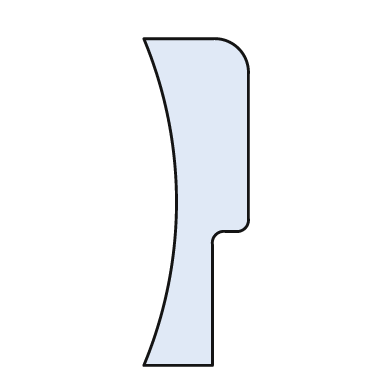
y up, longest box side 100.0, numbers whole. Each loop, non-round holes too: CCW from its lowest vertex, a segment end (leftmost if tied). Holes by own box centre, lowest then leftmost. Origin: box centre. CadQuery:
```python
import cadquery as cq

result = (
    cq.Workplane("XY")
    .moveTo(-16.0, -50.0)
    .lineTo(5.0, -50.0)
    .lineTo(5.0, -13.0)
    .threePointArc((6.0, -10.0), (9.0, -9.0))
    .lineTo(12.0, -9.0)
    .threePointArc((15.0, -8.0), (16.0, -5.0))
    .lineTo(16.0, 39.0)
    .threePointArc((13.0, 47.0), (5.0, 50.0))
    .lineTo(-16.0, 50.0)
    .threePointArc((-6.0, 0.0), (-16.0, -50.0))
    .close()
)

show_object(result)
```